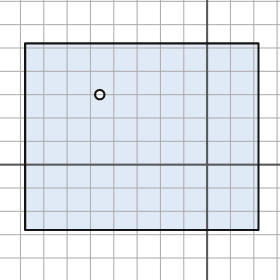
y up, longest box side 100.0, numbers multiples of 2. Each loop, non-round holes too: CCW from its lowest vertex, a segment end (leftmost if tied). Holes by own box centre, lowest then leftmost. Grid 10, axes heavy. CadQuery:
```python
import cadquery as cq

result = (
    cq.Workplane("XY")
    .moveTo(-78.0, -28.0)
    .lineTo(22.0, -28.0)
    .lineTo(22.0, 52.0)
    .lineTo(-78.0, 52.0)
    .close()
    .moveTo(-46.0, 30.0)
    .circle(2.0)
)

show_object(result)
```